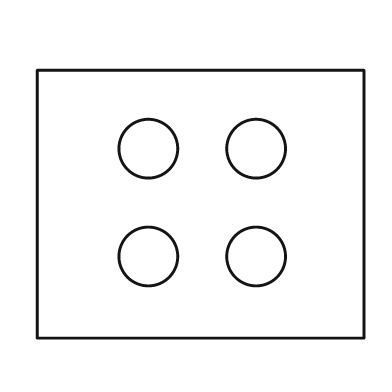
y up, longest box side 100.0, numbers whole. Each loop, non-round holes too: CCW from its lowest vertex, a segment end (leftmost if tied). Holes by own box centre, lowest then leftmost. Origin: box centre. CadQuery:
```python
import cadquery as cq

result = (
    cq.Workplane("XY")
    .moveTo(-50.0, -41.0)
    .lineTo(50.0, -41.0)
    .lineTo(50.0, 41.0)
    .lineTo(-50.0, 41.0)
    .close()
    .moveTo(-16.0, -16.0)
    .circle(9.0)
    .moveTo(17.0, -16.0)
    .circle(9.0)
    .moveTo(-16.0, 17.0)
    .circle(9.0)
    .moveTo(17.0, 17.0)
    .circle(9.0)
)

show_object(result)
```